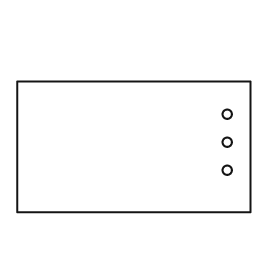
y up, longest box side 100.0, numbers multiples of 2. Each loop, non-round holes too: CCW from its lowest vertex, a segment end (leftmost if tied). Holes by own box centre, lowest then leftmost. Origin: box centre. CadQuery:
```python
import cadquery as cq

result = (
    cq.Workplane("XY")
    .moveTo(-50.0, -28.0)
    .lineTo(50.0, -28.0)
    .lineTo(50.0, 28.0)
    .lineTo(-50.0, 28.0)
    .close()
    .moveTo(40.0, -10.0)
    .circle(2.0)
    .moveTo(40.0, 2.0)
    .circle(2.0)
    .moveTo(40.0, 14.0)
    .circle(2.0)
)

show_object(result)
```